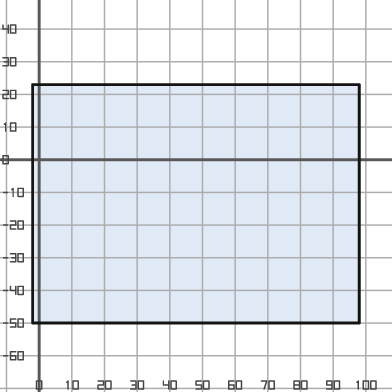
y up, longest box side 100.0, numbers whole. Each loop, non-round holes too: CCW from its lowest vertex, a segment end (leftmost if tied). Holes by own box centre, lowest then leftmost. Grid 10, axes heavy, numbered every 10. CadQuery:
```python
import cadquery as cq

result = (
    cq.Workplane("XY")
    .moveTo(-2.0, -50.0)
    .lineTo(98.0, -50.0)
    .lineTo(98.0, 23.0)
    .lineTo(-2.0, 23.0)
    .close()
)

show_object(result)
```